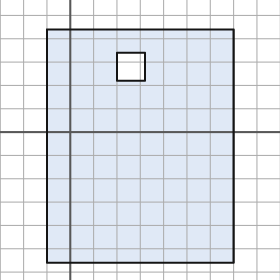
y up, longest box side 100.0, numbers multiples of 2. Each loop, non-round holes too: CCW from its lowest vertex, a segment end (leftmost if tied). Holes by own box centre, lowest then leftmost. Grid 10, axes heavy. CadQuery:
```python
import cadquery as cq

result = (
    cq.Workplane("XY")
    .moveTo(-10.0, -56.0)
    .lineTo(70.0, -56.0)
    .lineTo(70.0, 44.0)
    .lineTo(-10.0, 44.0)
    .close()
    .moveTo(20.0, 22.0)
    .lineTo(32.0, 22.0)
    .lineTo(32.0, 34.0)
    .lineTo(20.0, 34.0)
    .close()
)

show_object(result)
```